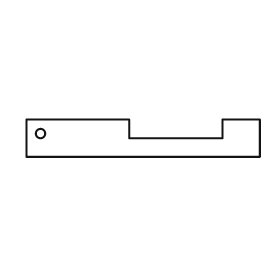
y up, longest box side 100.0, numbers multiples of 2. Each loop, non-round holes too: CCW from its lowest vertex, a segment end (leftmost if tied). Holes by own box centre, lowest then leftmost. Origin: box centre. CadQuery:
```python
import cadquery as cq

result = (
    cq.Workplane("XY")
    .moveTo(-50.0, -8.0)
    .lineTo(50.0, -8.0)
    .lineTo(50.0, 8.0)
    .lineTo(34.0, 8.0)
    .lineTo(34.0, 0.0)
    .lineTo(-6.0, 0.0)
    .lineTo(-6.0, 8.0)
    .lineTo(-50.0, 8.0)
    .close()
    .moveTo(-44.0, 2.0)
    .circle(2.0)
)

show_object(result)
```